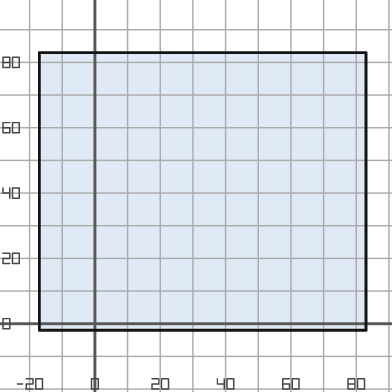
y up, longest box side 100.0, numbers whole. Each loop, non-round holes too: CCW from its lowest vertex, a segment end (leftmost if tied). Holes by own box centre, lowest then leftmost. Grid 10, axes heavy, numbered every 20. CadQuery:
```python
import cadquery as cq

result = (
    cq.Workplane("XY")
    .moveTo(-17.0, -2.0)
    .lineTo(83.0, -2.0)
    .lineTo(83.0, 83.0)
    .lineTo(-17.0, 83.0)
    .close()
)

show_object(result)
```